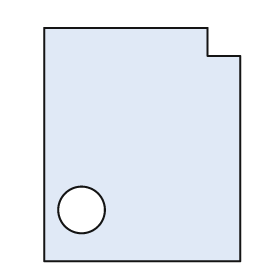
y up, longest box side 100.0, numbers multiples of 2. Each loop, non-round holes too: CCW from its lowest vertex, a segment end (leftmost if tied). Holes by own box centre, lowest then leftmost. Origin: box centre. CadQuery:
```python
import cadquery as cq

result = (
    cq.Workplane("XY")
    .moveTo(-42.0, -50.0)
    .lineTo(42.0, -50.0)
    .lineTo(42.0, 38.0)
    .lineTo(28.0, 38.0)
    .lineTo(28.0, 50.0)
    .lineTo(-42.0, 50.0)
    .close()
    .moveTo(-26.0, -28.0)
    .circle(10.0)
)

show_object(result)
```